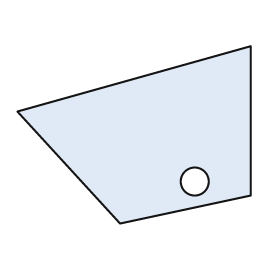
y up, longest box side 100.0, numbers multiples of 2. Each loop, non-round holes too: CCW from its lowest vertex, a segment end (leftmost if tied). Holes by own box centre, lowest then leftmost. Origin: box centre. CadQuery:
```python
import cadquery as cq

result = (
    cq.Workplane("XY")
    .moveTo(-6.0, -38.0)
    .lineTo(50.0, -26.0)
    .lineTo(50.0, 38.0)
    .lineTo(-50.0, 10.0)
    .close()
    .moveTo(26.0, -20.0)
    .circle(6.0)
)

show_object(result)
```